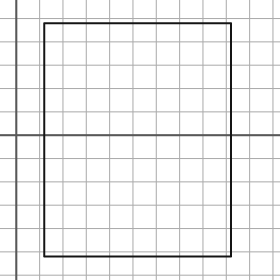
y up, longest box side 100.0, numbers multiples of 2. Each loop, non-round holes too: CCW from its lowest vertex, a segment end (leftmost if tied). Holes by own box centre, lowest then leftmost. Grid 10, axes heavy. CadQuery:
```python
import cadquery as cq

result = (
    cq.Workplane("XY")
    .moveTo(12.0, -52.0)
    .lineTo(92.0, -52.0)
    .lineTo(92.0, 48.0)
    .lineTo(12.0, 48.0)
    .close()
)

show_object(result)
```